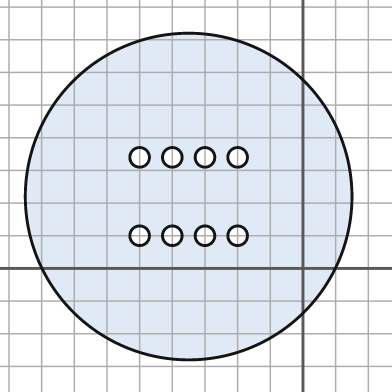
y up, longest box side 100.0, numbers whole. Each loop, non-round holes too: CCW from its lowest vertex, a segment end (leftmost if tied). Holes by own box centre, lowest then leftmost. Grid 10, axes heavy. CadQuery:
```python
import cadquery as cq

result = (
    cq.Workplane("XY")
    .moveTo(-35.0, 22.0)
    .circle(50.0)
    .moveTo(-50.0, 10.0)
    .circle(3.0)
    .moveTo(-40.0, 10.0)
    .circle(3.0)
    .moveTo(-30.0, 10.0)
    .circle(3.0)
    .moveTo(-20.0, 10.0)
    .circle(3.0)
    .moveTo(-50.0, 34.0)
    .circle(3.0)
    .moveTo(-40.0, 34.0)
    .circle(3.0)
    .moveTo(-30.0, 34.0)
    .circle(3.0)
    .moveTo(-20.0, 34.0)
    .circle(3.0)
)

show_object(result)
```